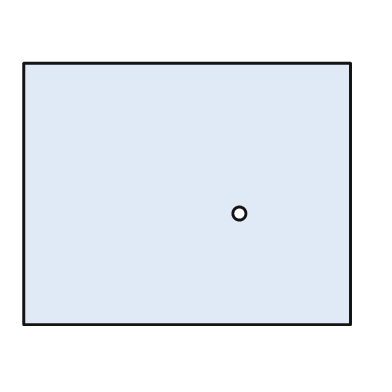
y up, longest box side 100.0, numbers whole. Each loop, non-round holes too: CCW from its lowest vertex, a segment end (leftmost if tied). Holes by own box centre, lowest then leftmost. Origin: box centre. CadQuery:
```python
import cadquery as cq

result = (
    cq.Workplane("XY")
    .moveTo(-50.0, -40.0)
    .lineTo(50.0, -40.0)
    .lineTo(50.0, 40.0)
    .lineTo(-50.0, 40.0)
    .close()
    .moveTo(16.0, -6.0)
    .circle(2.0)
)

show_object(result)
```